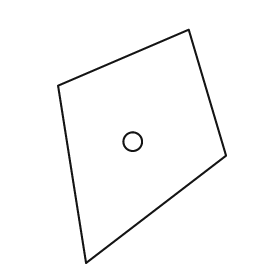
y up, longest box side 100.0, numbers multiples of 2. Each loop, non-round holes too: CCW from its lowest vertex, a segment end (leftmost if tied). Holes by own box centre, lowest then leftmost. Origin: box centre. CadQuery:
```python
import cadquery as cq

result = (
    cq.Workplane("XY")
    .moveTo(-24.0, -50.0)
    .lineTo(36.0, -4.0)
    .lineTo(20.0, 50.0)
    .lineTo(-36.0, 26.0)
    .close()
    .moveTo(-4.0, 2.0)
    .circle(4.0)
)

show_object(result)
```